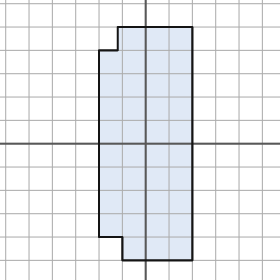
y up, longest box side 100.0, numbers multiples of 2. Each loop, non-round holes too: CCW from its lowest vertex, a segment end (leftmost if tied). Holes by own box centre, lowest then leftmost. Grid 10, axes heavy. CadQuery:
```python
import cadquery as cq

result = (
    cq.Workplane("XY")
    .moveTo(-10.0, -50.0)
    .lineTo(20.0, -50.0)
    .lineTo(20.0, 50.0)
    .lineTo(-12.0, 50.0)
    .lineTo(-12.0, 40.0)
    .lineTo(-20.0, 40.0)
    .lineTo(-20.0, -40.0)
    .lineTo(-10.0, -40.0)
    .close()
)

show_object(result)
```